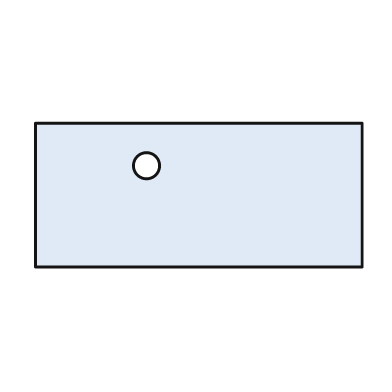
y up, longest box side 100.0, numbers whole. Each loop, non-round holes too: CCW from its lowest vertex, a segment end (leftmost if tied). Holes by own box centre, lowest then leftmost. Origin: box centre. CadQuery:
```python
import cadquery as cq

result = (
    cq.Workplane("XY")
    .moveTo(-50.0, -22.0)
    .lineTo(50.0, -22.0)
    .lineTo(50.0, 22.0)
    .lineTo(-50.0, 22.0)
    .close()
    .moveTo(-16.0, 9.0)
    .circle(4.0)
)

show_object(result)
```